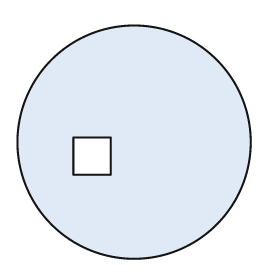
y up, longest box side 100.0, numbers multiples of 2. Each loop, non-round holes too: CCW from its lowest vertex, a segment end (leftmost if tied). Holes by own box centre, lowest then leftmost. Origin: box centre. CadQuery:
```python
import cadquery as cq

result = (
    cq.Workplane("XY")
    .moveTo(0.0, 0.0)
    .circle(50.0)
    .moveTo(-26.0, -14.0)
    .lineTo(-10.0, -14.0)
    .lineTo(-10.0, 2.0)
    .lineTo(-26.0, 2.0)
    .close()
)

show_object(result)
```